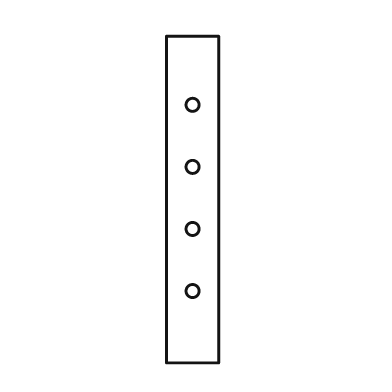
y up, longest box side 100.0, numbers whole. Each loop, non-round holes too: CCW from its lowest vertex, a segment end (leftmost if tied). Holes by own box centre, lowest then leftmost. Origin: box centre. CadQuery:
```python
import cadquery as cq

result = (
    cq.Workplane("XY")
    .moveTo(-8.0, -50.0)
    .lineTo(8.0, -50.0)
    .lineTo(8.0, 50.0)
    .lineTo(-8.0, 50.0)
    .close()
    .moveTo(0.0, -28.0)
    .circle(2.0)
    .moveTo(0.0, -9.0)
    .circle(2.0)
    .moveTo(0.0, 10.0)
    .circle(2.0)
    .moveTo(0.0, 29.0)
    .circle(2.0)
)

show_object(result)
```